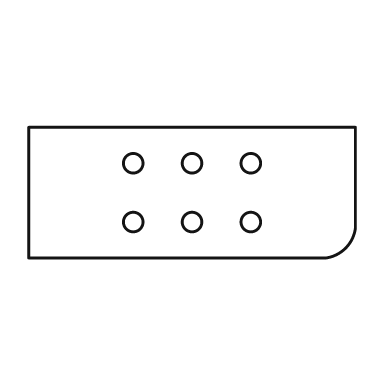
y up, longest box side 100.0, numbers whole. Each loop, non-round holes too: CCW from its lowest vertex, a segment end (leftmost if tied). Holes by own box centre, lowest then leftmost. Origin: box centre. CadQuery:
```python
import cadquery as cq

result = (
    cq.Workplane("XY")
    .moveTo(-50.0, -20.0)
    .lineTo(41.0, -20.0)
    .threePointArc((47.0, -17.0), (50.0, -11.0))
    .lineTo(50.0, 20.0)
    .lineTo(-50.0, 20.0)
    .close()
    .moveTo(-18.0, -9.0)
    .circle(3.0)
    .moveTo(0.0, -9.0)
    .circle(3.0)
    .moveTo(18.0, -9.0)
    .circle(3.0)
    .moveTo(-18.0, 9.0)
    .circle(3.0)
    .moveTo(0.0, 9.0)
    .circle(3.0)
    .moveTo(18.0, 9.0)
    .circle(3.0)
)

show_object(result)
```